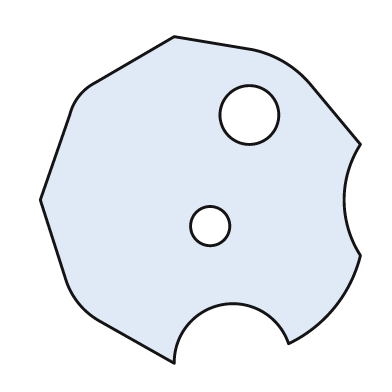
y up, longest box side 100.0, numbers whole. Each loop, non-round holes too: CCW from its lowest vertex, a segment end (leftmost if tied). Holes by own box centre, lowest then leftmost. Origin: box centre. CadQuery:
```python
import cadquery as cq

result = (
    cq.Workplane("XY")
    .moveTo(-8.0, -50.0)
    .threePointArc((7.0, -32.0), (27.0, -44.0))
    .threePointArc((41.0, -33.0), (49.0, -17.0))
    .threePointArc((44.0, 0.0), (49.0, 17.0))
    .lineTo(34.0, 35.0)
    .threePointArc((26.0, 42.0), (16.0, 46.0))
    .lineTo(-8.0, 50.0)
    .lineTo(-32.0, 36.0)
    .threePointArc((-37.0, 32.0), (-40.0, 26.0))
    .lineTo(-49.0, 0.0)
    .lineTo(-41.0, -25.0)
    .threePointArc((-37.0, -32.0), (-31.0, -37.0))
    .close()
    .moveTo(3.0, -8.0)
    .circle(6.0)
    .moveTo(15.0, 26.0)
    .circle(9.0)
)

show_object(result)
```